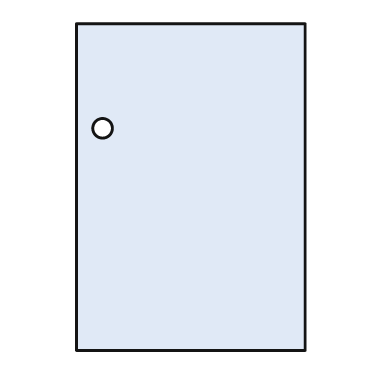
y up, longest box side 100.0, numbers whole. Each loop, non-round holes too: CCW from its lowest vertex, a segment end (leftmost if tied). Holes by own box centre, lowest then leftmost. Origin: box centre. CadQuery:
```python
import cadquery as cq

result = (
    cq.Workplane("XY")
    .moveTo(-35.0, -50.0)
    .lineTo(35.0, -50.0)
    .lineTo(35.0, 50.0)
    .lineTo(-35.0, 50.0)
    .close()
    .moveTo(-27.0, 18.0)
    .circle(3.0)
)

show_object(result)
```